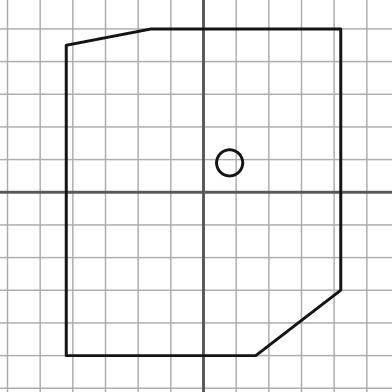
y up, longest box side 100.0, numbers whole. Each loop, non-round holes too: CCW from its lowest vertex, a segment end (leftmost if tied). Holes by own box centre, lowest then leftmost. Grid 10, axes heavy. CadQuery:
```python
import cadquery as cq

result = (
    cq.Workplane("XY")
    .moveTo(-42.0, -50.0)
    .lineTo(16.0, -50.0)
    .lineTo(42.0, -30.0)
    .lineTo(42.0, 50.0)
    .lineTo(-16.0, 50.0)
    .lineTo(-42.0, 45.0)
    .close()
    .moveTo(8.0, 9.0)
    .circle(4.0)
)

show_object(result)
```